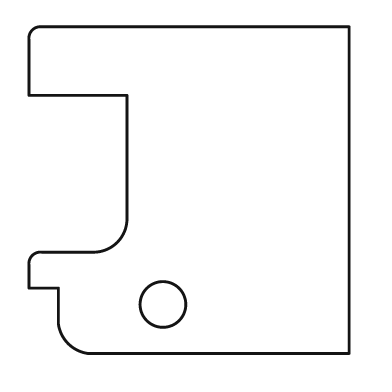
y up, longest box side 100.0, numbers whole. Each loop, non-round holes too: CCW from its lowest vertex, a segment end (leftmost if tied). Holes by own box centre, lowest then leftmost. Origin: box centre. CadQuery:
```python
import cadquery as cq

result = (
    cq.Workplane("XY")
    .moveTo(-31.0, -50.0)
    .lineTo(49.0, -50.0)
    .lineTo(49.0, 50.0)
    .lineTo(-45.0, 50.0)
    .threePointArc((-48.0, 49.0), (-49.0, 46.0))
    .lineTo(-49.0, 29.0)
    .lineTo(-19.0, 29.0)
    .lineTo(-19.0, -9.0)
    .threePointArc((-22.0, -16.0), (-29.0, -19.0))
    .lineTo(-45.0, -19.0)
    .threePointArc((-48.0, -20.0), (-49.0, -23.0))
    .lineTo(-49.0, -30.0)
    .lineTo(-40.0, -30.0)
    .lineTo(-40.0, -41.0)
    .threePointArc((-37.0, -47.0), (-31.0, -50.0))
    .close()
    .moveTo(-8.0, -35.0)
    .circle(7.0)
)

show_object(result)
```